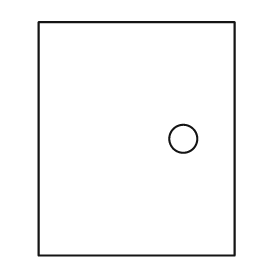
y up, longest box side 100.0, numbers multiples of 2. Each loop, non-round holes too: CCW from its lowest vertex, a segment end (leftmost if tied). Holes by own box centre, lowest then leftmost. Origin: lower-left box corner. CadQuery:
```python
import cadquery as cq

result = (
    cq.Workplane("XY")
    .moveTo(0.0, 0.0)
    .lineTo(84.0, 0.0)
    .lineTo(84.0, 100.0)
    .lineTo(0.0, 100.0)
    .close()
    .moveTo(62.0, 50.0)
    .circle(6.0)
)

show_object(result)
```